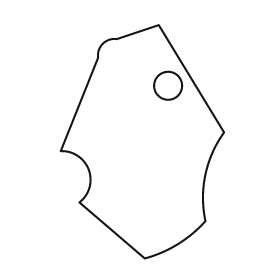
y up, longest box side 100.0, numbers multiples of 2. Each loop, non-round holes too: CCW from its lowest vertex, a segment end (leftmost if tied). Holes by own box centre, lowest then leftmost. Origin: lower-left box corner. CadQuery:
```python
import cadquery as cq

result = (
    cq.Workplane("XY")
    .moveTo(36.0, 0.0)
    .threePointArc((50.0, 6.0), (62.0, 16.0))
    .threePointArc((62.0, 36.0), (70.0, 54.0))
    .lineTo(42.0, 100.0)
    .lineTo(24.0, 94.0)
    .threePointArc((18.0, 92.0), (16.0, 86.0))
    .lineTo(0.0, 46.0)
    .threePointArc((12.0, 38.0), (8.0, 24.0))
    .close()
    .moveTo(46.0, 74.0)
    .circle(6.0)
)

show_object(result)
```